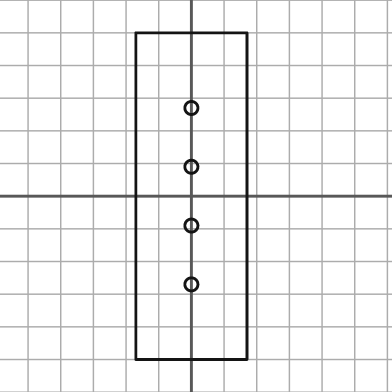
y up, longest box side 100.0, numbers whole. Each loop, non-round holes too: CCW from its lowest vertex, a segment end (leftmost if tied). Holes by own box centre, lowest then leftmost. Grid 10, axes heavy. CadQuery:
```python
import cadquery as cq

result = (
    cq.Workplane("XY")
    .moveTo(-17.0, -50.0)
    .lineTo(17.0, -50.0)
    .lineTo(17.0, 50.0)
    .lineTo(-17.0, 50.0)
    .close()
    .moveTo(0.0, -27.0)
    .circle(2.0)
    .moveTo(0.0, -9.0)
    .circle(2.0)
    .moveTo(0.0, 9.0)
    .circle(2.0)
    .moveTo(0.0, 27.0)
    .circle(2.0)
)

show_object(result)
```